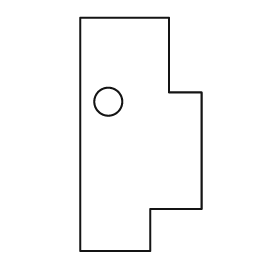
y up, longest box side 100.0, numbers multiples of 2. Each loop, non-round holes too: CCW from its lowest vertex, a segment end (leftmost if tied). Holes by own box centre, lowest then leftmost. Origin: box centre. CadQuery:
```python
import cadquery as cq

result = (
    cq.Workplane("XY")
    .moveTo(-26.0, -50.0)
    .lineTo(4.0, -50.0)
    .lineTo(4.0, -32.0)
    .lineTo(26.0, -32.0)
    .lineTo(26.0, 18.0)
    .lineTo(12.0, 18.0)
    .lineTo(12.0, 50.0)
    .lineTo(-26.0, 50.0)
    .close()
    .moveTo(-14.0, 14.0)
    .circle(6.0)
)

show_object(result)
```